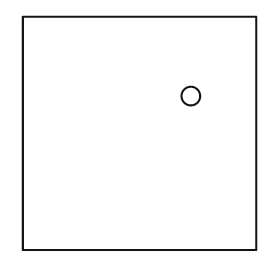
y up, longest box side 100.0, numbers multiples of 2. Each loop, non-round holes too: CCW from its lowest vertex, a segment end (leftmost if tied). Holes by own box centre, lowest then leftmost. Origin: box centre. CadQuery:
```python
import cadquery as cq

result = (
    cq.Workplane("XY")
    .moveTo(-50.0, -50.0)
    .lineTo(50.0, -50.0)
    .lineTo(50.0, 50.0)
    .lineTo(-50.0, 50.0)
    .close()
    .moveTo(22.0, 16.0)
    .circle(4.0)
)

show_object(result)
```